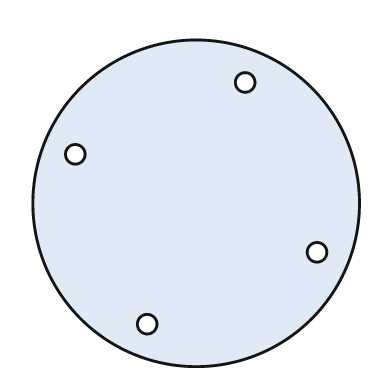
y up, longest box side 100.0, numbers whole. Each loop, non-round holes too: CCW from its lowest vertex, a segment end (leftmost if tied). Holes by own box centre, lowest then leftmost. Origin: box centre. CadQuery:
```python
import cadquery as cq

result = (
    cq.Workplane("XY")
    .moveTo(0.0, 0.0)
    .circle(50.0)
    .moveTo(-15.0, -37.0)
    .circle(3.0)
    .moveTo(37.0, -15.0)
    .circle(3.0)
    .moveTo(-37.0, 15.0)
    .circle(3.0)
    .moveTo(15.0, 37.0)
    .circle(3.0)
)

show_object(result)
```